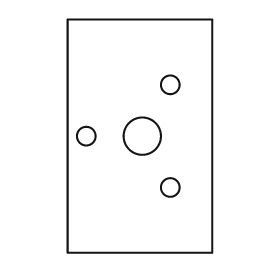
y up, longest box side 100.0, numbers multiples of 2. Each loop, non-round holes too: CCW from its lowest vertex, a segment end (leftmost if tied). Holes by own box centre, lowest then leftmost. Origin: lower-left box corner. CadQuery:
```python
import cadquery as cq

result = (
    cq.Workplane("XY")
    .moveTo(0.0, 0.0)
    .lineTo(62.0, 0.0)
    .lineTo(62.0, 100.0)
    .lineTo(0.0, 100.0)
    .close()
    .moveTo(44.0, 28.0)
    .circle(4.0)
    .moveTo(8.0, 50.0)
    .circle(4.0)
    .moveTo(32.0, 50.0)
    .circle(8.0)
    .moveTo(44.0, 72.0)
    .circle(4.0)
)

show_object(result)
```